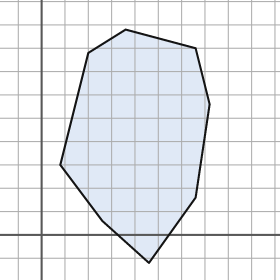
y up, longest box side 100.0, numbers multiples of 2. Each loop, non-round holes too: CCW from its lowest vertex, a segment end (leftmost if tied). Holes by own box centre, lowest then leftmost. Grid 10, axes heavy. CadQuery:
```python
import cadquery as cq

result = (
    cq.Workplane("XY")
    .moveTo(46.0, -12.0)
    .lineTo(66.0, 16.0)
    .lineTo(72.0, 56.0)
    .lineTo(66.0, 80.0)
    .lineTo(36.0, 88.0)
    .lineTo(20.0, 78.0)
    .lineTo(8.0, 30.0)
    .lineTo(26.0, 6.0)
    .close()
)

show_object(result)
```